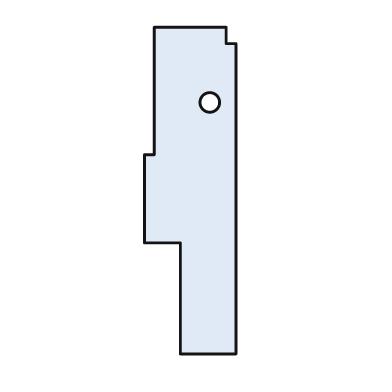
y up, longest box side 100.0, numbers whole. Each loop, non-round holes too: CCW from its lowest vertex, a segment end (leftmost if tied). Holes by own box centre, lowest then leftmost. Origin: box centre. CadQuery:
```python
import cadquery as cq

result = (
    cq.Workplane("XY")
    .moveTo(-3.0, -50.0)
    .lineTo(14.0, -50.0)
    .lineTo(14.0, 45.0)
    .lineTo(11.0, 45.0)
    .lineTo(11.0, 50.0)
    .lineTo(-11.0, 50.0)
    .lineTo(-11.0, 11.0)
    .lineTo(-14.0, 11.0)
    .lineTo(-14.0, -16.0)
    .lineTo(-3.0, -16.0)
    .close()
    .moveTo(6.0, 27.0)
    .circle(3.0)
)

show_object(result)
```